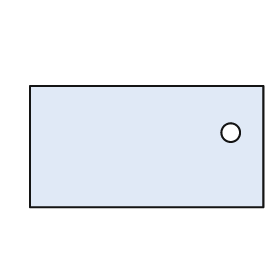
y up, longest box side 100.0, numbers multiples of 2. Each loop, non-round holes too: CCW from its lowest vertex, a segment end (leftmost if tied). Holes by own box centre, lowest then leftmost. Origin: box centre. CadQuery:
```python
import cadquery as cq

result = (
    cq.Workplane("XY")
    .moveTo(-50.0, -26.0)
    .lineTo(50.0, -26.0)
    .lineTo(50.0, 26.0)
    .lineTo(-50.0, 26.0)
    .close()
    .moveTo(36.0, 6.0)
    .circle(4.0)
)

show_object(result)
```